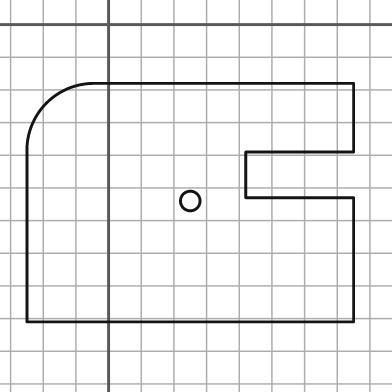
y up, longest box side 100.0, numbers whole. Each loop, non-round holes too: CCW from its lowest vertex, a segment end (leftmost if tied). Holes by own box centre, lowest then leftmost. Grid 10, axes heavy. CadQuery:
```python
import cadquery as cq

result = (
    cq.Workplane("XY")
    .moveTo(-25.0, -91.0)
    .lineTo(75.0, -91.0)
    .lineTo(75.0, -53.0)
    .lineTo(42.0, -53.0)
    .lineTo(42.0, -39.0)
    .lineTo(75.0, -39.0)
    .lineTo(75.0, -18.0)
    .lineTo(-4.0, -18.0)
    .threePointArc((-19.0, -24.0), (-25.0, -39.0))
    .close()
    .moveTo(25.0, -54.0)
    .circle(3.0)
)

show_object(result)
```